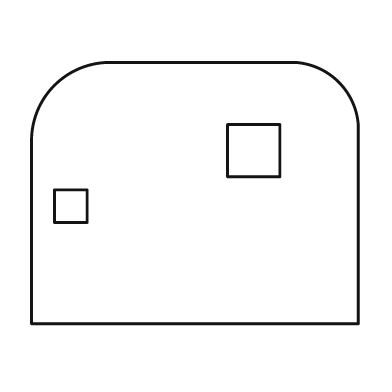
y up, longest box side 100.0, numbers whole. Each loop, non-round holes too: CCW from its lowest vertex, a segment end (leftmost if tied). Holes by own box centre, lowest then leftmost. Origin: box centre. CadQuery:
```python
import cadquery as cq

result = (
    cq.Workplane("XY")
    .moveTo(-50.0, -40.0)
    .lineTo(50.0, -40.0)
    .lineTo(50.0, 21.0)
    .threePointArc((44.0, 34.0), (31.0, 40.0))
    .lineTo(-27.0, 40.0)
    .threePointArc((-43.0, 33.0), (-50.0, 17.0))
    .close()
    .moveTo(-43.0, -9.0)
    .lineTo(-33.0, -9.0)
    .lineTo(-33.0, 1.0)
    .lineTo(-43.0, 1.0)
    .close()
    .moveTo(10.0, 5.0)
    .lineTo(26.0, 5.0)
    .lineTo(26.0, 21.0)
    .lineTo(10.0, 21.0)
    .close()
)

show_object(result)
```